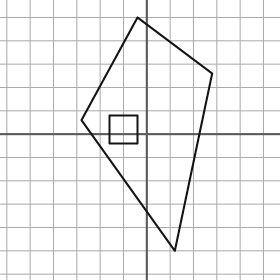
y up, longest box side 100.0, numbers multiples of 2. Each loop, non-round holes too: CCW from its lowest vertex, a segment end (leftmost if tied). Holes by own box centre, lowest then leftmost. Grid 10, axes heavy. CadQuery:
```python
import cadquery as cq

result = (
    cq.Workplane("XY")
    .moveTo(12.0, -50.0)
    .lineTo(28.0, 26.0)
    .lineTo(-4.0, 50.0)
    .lineTo(-28.0, 6.0)
    .close()
    .moveTo(-16.0, -4.0)
    .lineTo(-4.0, -4.0)
    .lineTo(-4.0, 8.0)
    .lineTo(-16.0, 8.0)
    .close()
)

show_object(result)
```